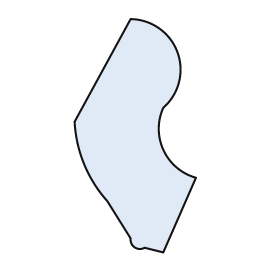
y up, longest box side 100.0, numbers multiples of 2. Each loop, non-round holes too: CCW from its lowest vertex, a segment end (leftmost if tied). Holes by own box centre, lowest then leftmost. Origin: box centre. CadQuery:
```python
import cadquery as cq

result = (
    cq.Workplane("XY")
    .moveTo(12.0, -50.0)
    .lineTo(26.0, -18.0)
    .threePointArc((12.0, -6.0), (12.0, 12.0))
    .threePointArc((18.0, 36.0), (-2.0, 50.0))
    .lineTo(-26.0, 6.0)
    .threePointArc((-22.0, -12.0), (-12.0, -28.0))
    .lineTo(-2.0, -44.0)
    .threePointArc((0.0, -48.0), (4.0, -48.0))
    .close()
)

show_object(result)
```